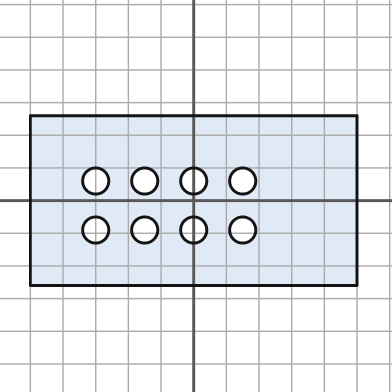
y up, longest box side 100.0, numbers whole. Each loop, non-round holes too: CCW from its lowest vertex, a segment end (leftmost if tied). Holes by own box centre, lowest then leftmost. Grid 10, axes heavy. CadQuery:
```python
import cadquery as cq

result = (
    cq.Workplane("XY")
    .moveTo(-50.0, -26.0)
    .lineTo(50.0, -26.0)
    .lineTo(50.0, 26.0)
    .lineTo(-50.0, 26.0)
    .close()
    .moveTo(-30.0, -9.0)
    .circle(4.0)
    .moveTo(-15.0, -9.0)
    .circle(4.0)
    .moveTo(0.0, -9.0)
    .circle(4.0)
    .moveTo(15.0, -9.0)
    .circle(4.0)
    .moveTo(-30.0, 6.0)
    .circle(4.0)
    .moveTo(-15.0, 6.0)
    .circle(4.0)
    .moveTo(0.0, 6.0)
    .circle(4.0)
    .moveTo(15.0, 6.0)
    .circle(4.0)
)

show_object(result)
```